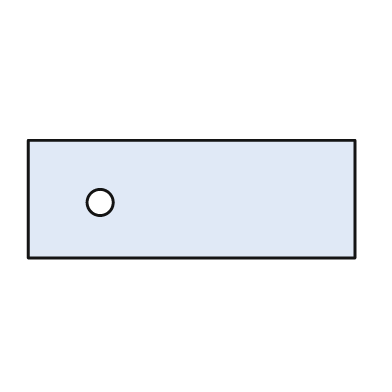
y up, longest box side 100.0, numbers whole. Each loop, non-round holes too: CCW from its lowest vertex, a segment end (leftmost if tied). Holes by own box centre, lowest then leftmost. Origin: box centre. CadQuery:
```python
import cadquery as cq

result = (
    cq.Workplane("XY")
    .moveTo(-50.0, -18.0)
    .lineTo(50.0, -18.0)
    .lineTo(50.0, 18.0)
    .lineTo(-50.0, 18.0)
    .close()
    .moveTo(-28.0, -1.0)
    .circle(4.0)
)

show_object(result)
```